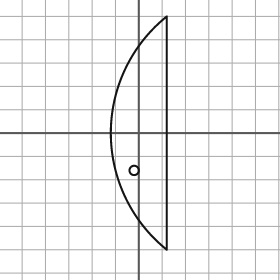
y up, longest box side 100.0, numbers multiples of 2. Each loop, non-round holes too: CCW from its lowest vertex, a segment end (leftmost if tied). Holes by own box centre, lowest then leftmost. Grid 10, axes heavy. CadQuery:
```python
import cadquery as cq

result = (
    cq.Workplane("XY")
    .moveTo(12.0, -50.0)
    .lineTo(12.0, 50.0)
    .threePointArc((-12.0, 0.0), (12.0, -50.0))
    .close()
    .moveTo(-2.0, -16.0)
    .circle(2.0)
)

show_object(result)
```